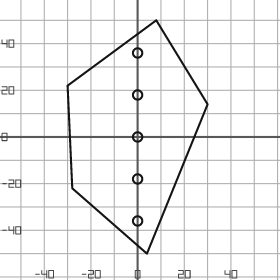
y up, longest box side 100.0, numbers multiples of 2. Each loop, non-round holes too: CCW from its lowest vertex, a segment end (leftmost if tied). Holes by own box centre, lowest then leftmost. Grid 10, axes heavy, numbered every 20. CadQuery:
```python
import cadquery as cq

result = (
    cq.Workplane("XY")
    .moveTo(4.0, -50.0)
    .lineTo(30.0, 14.0)
    .lineTo(8.0, 50.0)
    .lineTo(-30.0, 22.0)
    .lineTo(-28.0, -22.0)
    .close()
    .moveTo(0.0, -36.0)
    .circle(2.0)
    .moveTo(0.0, -18.0)
    .circle(2.0)
    .moveTo(0.0, 0.0)
    .circle(2.0)
    .moveTo(0.0, 18.0)
    .circle(2.0)
    .moveTo(0.0, 36.0)
    .circle(2.0)
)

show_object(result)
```